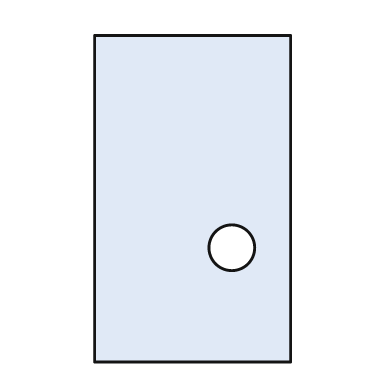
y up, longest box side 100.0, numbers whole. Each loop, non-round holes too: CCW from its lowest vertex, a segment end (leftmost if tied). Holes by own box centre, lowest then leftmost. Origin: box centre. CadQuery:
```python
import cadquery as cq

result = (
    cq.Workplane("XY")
    .moveTo(-30.0, -50.0)
    .lineTo(30.0, -50.0)
    .lineTo(30.0, 50.0)
    .lineTo(-30.0, 50.0)
    .close()
    .moveTo(12.0, -15.0)
    .circle(7.0)
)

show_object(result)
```